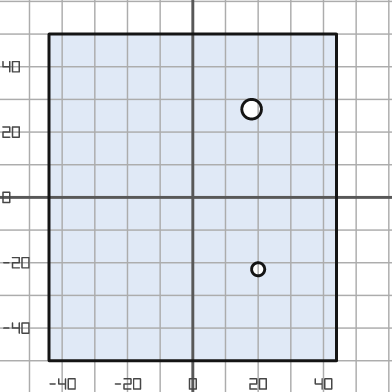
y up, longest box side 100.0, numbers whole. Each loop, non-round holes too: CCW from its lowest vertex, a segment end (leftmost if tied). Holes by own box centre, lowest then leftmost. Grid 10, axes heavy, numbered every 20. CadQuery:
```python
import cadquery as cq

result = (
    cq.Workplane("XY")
    .moveTo(-44.0, -50.0)
    .lineTo(44.0, -50.0)
    .lineTo(44.0, 50.0)
    .lineTo(-44.0, 50.0)
    .close()
    .moveTo(20.0, -22.0)
    .circle(2.0)
    .moveTo(18.0, 27.0)
    .circle(3.0)
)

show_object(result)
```